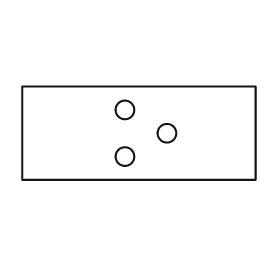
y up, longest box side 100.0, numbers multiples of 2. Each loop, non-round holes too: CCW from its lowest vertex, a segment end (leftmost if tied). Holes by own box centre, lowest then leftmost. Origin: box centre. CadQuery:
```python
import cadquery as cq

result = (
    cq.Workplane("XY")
    .moveTo(-50.0, -20.0)
    .lineTo(50.0, -20.0)
    .lineTo(50.0, 20.0)
    .lineTo(-50.0, 20.0)
    .close()
    .moveTo(-6.0, -10.0)
    .circle(4.0)
    .moveTo(12.0, 0.0)
    .circle(4.0)
    .moveTo(-6.0, 10.0)
    .circle(4.0)
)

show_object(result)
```